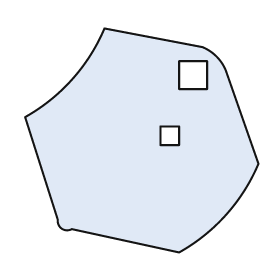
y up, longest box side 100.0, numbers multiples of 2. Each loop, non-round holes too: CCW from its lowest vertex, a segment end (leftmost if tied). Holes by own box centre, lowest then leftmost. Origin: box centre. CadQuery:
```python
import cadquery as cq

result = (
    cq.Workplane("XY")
    .moveTo(16.0, -48.0)
    .threePointArc((36.0, -32.0), (50.0, -10.0))
    .lineTo(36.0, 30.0)
    .threePointArc((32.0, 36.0), (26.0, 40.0))
    .lineTo(-16.0, 48.0)
    .threePointArc((-30.0, 26.0), (-50.0, 10.0))
    .lineTo(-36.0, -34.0)
    .threePointArc((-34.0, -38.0), (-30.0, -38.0))
    .close()
    .moveTo(8.0, -2.0)
    .lineTo(16.0, -2.0)
    .lineTo(16.0, 6.0)
    .lineTo(8.0, 6.0)
    .close()
    .moveTo(16.0, 22.0)
    .lineTo(28.0, 22.0)
    .lineTo(28.0, 34.0)
    .lineTo(16.0, 34.0)
    .close()
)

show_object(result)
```